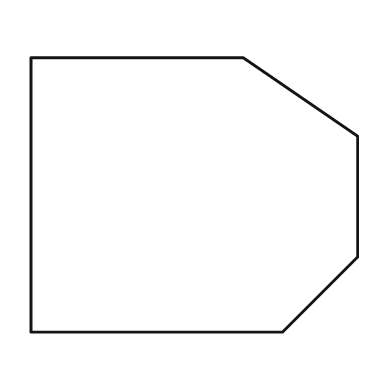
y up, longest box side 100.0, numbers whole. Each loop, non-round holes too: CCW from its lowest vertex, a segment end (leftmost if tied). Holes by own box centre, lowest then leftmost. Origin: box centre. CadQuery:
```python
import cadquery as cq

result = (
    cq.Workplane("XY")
    .moveTo(-50.0, -42.0)
    .lineTo(27.0, -42.0)
    .lineTo(50.0, -19.0)
    .lineTo(50.0, 18.0)
    .lineTo(15.0, 42.0)
    .lineTo(-50.0, 42.0)
    .close()
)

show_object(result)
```